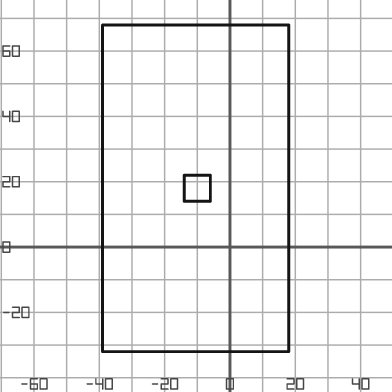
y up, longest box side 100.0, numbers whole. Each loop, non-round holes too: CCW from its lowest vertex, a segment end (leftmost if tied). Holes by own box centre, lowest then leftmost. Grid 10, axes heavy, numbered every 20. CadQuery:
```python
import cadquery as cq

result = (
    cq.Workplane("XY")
    .moveTo(-39.0, -32.0)
    .lineTo(18.0, -32.0)
    .lineTo(18.0, 68.0)
    .lineTo(-39.0, 68.0)
    .close()
    .moveTo(-14.0, 14.0)
    .lineTo(-6.0, 14.0)
    .lineTo(-6.0, 22.0)
    .lineTo(-14.0, 22.0)
    .close()
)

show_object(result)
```